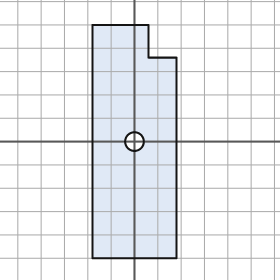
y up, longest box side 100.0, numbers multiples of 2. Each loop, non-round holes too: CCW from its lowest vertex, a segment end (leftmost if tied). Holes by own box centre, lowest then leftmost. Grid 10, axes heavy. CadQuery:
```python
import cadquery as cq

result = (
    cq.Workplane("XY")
    .moveTo(-18.0, -50.0)
    .lineTo(18.0, -50.0)
    .lineTo(18.0, 36.0)
    .lineTo(6.0, 36.0)
    .lineTo(6.0, 50.0)
    .lineTo(-18.0, 50.0)
    .close()
    .moveTo(0.0, 0.0)
    .circle(4.0)
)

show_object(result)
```